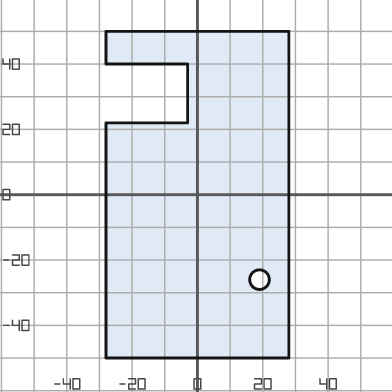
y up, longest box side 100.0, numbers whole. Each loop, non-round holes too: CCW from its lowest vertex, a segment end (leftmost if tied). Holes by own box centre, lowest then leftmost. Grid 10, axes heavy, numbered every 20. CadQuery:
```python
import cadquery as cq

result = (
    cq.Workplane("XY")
    .moveTo(-28.0, -50.0)
    .lineTo(28.0, -50.0)
    .lineTo(28.0, 50.0)
    .lineTo(-28.0, 50.0)
    .lineTo(-28.0, 40.0)
    .lineTo(-3.0, 40.0)
    .lineTo(-3.0, 22.0)
    .lineTo(-28.0, 22.0)
    .close()
    .moveTo(19.0, -26.0)
    .circle(3.0)
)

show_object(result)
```